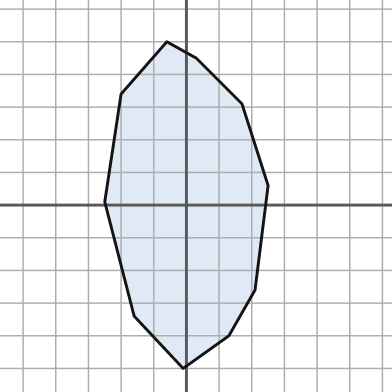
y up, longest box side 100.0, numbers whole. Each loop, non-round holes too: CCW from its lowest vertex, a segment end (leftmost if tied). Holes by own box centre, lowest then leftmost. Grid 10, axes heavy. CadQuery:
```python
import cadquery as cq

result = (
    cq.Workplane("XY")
    .moveTo(-1.0, -50.0)
    .lineTo(13.0, -40.0)
    .lineTo(21.0, -26.0)
    .lineTo(25.0, 6.0)
    .lineTo(17.0, 31.0)
    .lineTo(3.0, 45.0)
    .lineTo(-6.0, 50.0)
    .lineTo(-20.0, 34.0)
    .lineTo(-25.0, 1.0)
    .lineTo(-16.0, -34.0)
    .close()
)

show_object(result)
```